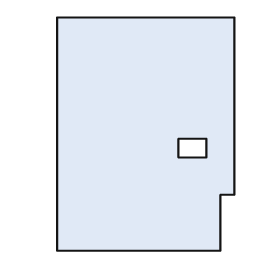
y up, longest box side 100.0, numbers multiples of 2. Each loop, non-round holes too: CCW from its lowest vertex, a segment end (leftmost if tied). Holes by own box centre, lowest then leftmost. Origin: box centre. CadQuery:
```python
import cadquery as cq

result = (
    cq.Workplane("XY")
    .moveTo(-38.0, -50.0)
    .lineTo(32.0, -50.0)
    .lineTo(32.0, -26.0)
    .lineTo(38.0, -26.0)
    .lineTo(38.0, 50.0)
    .lineTo(-38.0, 50.0)
    .close()
    .moveTo(14.0, -10.0)
    .lineTo(26.0, -10.0)
    .lineTo(26.0, -2.0)
    .lineTo(14.0, -2.0)
    .close()
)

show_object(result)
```